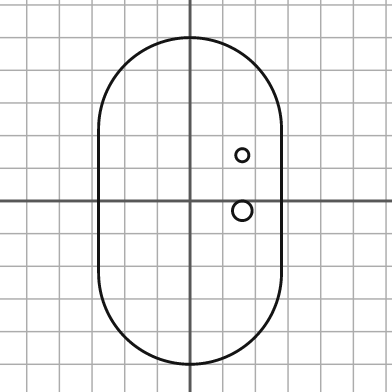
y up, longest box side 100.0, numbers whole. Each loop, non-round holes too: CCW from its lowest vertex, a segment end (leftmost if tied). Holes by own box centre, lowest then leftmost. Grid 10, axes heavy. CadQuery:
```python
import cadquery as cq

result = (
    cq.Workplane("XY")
    .moveTo(-28.0, -22.0)
    .threePointArc((0.0, -50.0), (28.0, -22.0))
    .lineTo(28.0, 22.0)
    .threePointArc((0.0, 50.0), (-28.0, 22.0))
    .close()
    .moveTo(16.0, -3.0)
    .circle(3.0)
    .moveTo(16.0, 14.0)
    .circle(2.0)
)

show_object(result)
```